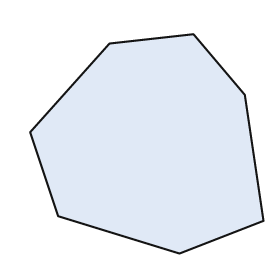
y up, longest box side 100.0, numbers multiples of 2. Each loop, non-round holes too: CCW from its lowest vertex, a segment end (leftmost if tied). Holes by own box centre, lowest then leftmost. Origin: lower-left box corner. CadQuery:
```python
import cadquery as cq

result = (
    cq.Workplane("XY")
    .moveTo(64.0, 0.0)
    .lineTo(100.0, 14.0)
    .lineTo(92.0, 68.0)
    .lineTo(70.0, 94.0)
    .lineTo(34.0, 90.0)
    .lineTo(0.0, 52.0)
    .lineTo(12.0, 16.0)
    .close()
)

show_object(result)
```